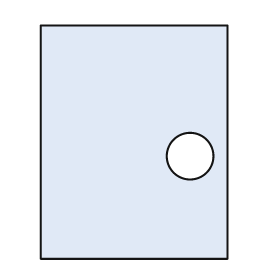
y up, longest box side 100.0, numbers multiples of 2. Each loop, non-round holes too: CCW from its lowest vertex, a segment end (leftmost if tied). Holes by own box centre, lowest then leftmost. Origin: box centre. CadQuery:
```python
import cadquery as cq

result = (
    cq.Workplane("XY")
    .moveTo(-40.0, -50.0)
    .lineTo(40.0, -50.0)
    .lineTo(40.0, 50.0)
    .lineTo(-40.0, 50.0)
    .close()
    .moveTo(24.0, -6.0)
    .circle(10.0)
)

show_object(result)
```